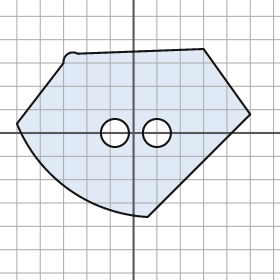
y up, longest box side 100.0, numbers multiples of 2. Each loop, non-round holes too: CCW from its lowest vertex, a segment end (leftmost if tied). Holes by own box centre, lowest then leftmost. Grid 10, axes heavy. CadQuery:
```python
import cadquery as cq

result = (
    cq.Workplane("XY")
    .moveTo(6.0, -36.0)
    .lineTo(50.0, 8.0)
    .lineTo(30.0, 36.0)
    .lineTo(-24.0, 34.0)
    .threePointArc((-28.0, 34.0), (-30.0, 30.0))
    .lineTo(-50.0, 4.0)
    .threePointArc((-28.0, -24.0), (6.0, -36.0))
    .close()
    .moveTo(-8.0, 0.0)
    .circle(6.0)
    .moveTo(10.0, 0.0)
    .circle(6.0)
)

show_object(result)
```